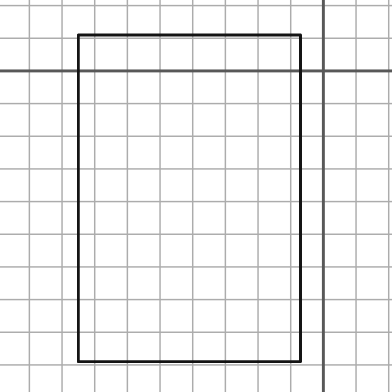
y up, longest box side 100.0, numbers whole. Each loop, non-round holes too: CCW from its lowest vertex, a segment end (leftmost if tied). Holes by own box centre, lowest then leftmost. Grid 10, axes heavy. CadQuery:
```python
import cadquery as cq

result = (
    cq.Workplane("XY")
    .moveTo(-75.0, -89.0)
    .lineTo(-7.0, -89.0)
    .lineTo(-7.0, 11.0)
    .lineTo(-75.0, 11.0)
    .close()
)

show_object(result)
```